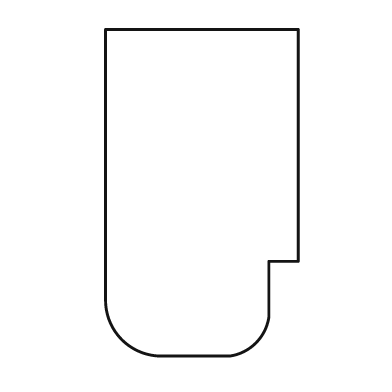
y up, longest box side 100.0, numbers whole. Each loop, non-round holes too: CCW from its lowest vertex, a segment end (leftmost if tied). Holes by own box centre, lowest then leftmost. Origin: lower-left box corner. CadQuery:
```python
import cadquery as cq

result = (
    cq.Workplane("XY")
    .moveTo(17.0, 0.0)
    .lineTo(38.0, 0.0)
    .threePointArc((46.0, 4.0), (50.0, 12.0))
    .lineTo(50.0, 29.0)
    .lineTo(59.0, 29.0)
    .lineTo(59.0, 100.0)
    .lineTo(0.0, 100.0)
    .lineTo(0.0, 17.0)
    .threePointArc((5.0, 5.0), (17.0, 0.0))
    .close()
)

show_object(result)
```